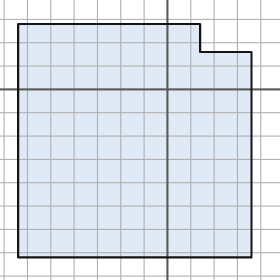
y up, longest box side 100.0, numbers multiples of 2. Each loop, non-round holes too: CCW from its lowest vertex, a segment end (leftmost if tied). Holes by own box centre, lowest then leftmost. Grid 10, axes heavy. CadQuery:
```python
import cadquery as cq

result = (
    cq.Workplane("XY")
    .moveTo(-64.0, -72.0)
    .lineTo(36.0, -72.0)
    .lineTo(36.0, 16.0)
    .lineTo(14.0, 16.0)
    .lineTo(14.0, 28.0)
    .lineTo(-64.0, 28.0)
    .close()
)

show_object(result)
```